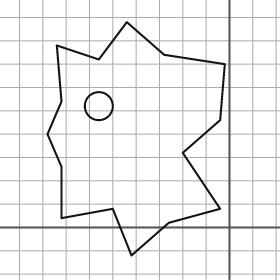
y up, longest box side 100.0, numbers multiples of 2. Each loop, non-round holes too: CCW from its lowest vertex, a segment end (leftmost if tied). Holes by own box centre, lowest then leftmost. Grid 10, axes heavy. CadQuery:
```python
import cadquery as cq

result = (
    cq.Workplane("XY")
    .moveTo(-42.0, -12.0)
    .lineTo(-26.0, 2.0)
    .lineTo(-4.0, 8.0)
    .lineTo(-20.0, 32.0)
    .lineTo(-4.0, 46.0)
    .lineTo(-2.0, 70.0)
    .lineTo(-28.0, 74.0)
    .lineTo(-44.0, 88.0)
    .lineTo(-56.0, 72.0)
    .lineTo(-74.0, 78.0)
    .lineTo(-72.0, 54.0)
    .lineTo(-78.0, 40.0)
    .lineTo(-72.0, 26.0)
    .lineTo(-72.0, 4.0)
    .lineTo(-50.0, 8.0)
    .close()
    .moveTo(-56.0, 52.0)
    .circle(6.0)
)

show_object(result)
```